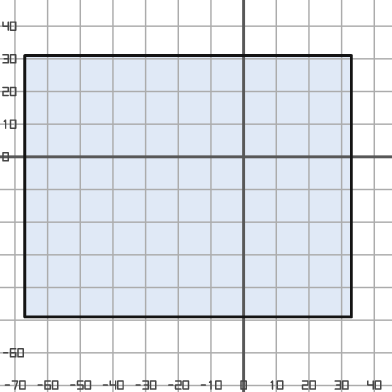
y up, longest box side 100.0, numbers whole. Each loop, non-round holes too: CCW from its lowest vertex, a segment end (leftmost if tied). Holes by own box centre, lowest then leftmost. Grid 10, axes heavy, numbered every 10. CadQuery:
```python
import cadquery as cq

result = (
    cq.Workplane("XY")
    .moveTo(-67.0, -49.0)
    .lineTo(33.0, -49.0)
    .lineTo(33.0, 31.0)
    .lineTo(-67.0, 31.0)
    .close()
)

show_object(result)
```